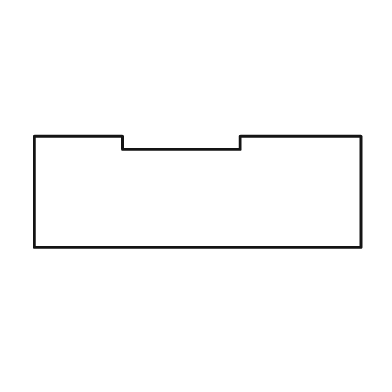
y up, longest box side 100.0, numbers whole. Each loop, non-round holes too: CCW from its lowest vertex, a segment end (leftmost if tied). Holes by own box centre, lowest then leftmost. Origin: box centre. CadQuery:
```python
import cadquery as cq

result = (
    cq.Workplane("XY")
    .moveTo(-50.0, -17.0)
    .lineTo(50.0, -17.0)
    .lineTo(50.0, 17.0)
    .lineTo(13.0, 17.0)
    .lineTo(13.0, 13.0)
    .lineTo(-23.0, 13.0)
    .lineTo(-23.0, 17.0)
    .lineTo(-50.0, 17.0)
    .close()
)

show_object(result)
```